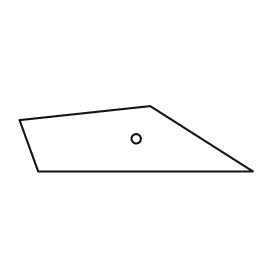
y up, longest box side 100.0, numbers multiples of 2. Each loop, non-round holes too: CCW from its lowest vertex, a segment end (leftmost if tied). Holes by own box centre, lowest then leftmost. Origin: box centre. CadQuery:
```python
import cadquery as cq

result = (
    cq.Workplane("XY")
    .moveTo(-42.0, -14.0)
    .lineTo(50.0, -14.0)
    .lineTo(6.0, 14.0)
    .lineTo(-50.0, 8.0)
    .close()
    .moveTo(0.0, 0.0)
    .circle(2.0)
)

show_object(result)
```